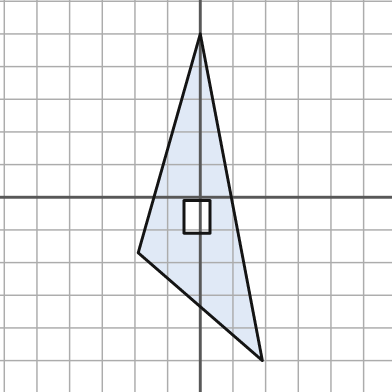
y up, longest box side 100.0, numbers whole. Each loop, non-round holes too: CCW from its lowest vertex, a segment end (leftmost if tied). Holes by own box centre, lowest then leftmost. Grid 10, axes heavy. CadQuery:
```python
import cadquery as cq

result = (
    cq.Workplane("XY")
    .moveTo(19.0, -50.0)
    .lineTo(0.0, 50.0)
    .lineTo(-19.0, -17.0)
    .close()
    .moveTo(-5.0, -11.0)
    .lineTo(3.0, -11.0)
    .lineTo(3.0, -1.0)
    .lineTo(-5.0, -1.0)
    .close()
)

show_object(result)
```